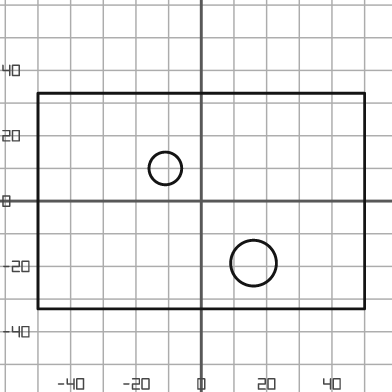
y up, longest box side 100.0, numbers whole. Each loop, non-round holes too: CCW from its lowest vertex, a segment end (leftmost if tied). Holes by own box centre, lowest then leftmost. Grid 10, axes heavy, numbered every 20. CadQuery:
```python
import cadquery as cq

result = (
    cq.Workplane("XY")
    .moveTo(-50.0, -33.0)
    .lineTo(50.0, -33.0)
    .lineTo(50.0, 33.0)
    .lineTo(-50.0, 33.0)
    .close()
    .moveTo(16.0, -19.0)
    .circle(7.0)
    .moveTo(-11.0, 10.0)
    .circle(5.0)
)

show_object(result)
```